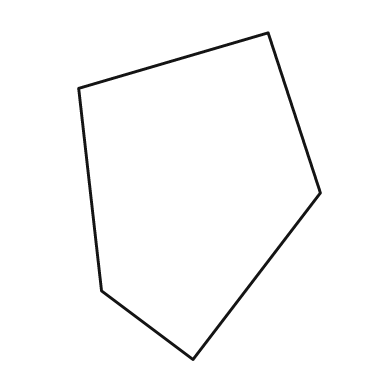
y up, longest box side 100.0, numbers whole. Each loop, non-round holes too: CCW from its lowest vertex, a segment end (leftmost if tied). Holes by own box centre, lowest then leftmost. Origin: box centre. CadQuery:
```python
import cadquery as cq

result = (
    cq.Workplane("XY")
    .moveTo(-2.0, -50.0)
    .lineTo(37.0, 1.0)
    .lineTo(21.0, 50.0)
    .lineTo(-37.0, 33.0)
    .lineTo(-30.0, -29.0)
    .close()
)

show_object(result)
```